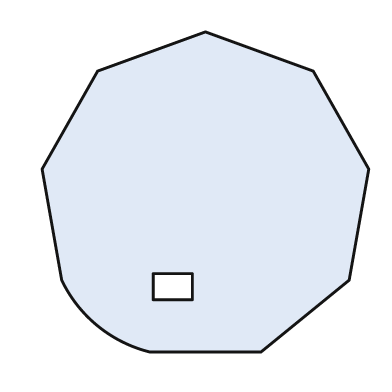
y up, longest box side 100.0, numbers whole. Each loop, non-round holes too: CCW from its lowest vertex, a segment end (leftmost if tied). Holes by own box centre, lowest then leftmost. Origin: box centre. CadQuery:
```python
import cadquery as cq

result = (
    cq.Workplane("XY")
    .moveTo(-17.0, -49.0)
    .lineTo(17.0, -49.0)
    .lineTo(44.0, -27.0)
    .lineTo(50.0, 7.0)
    .lineTo(33.0, 37.0)
    .lineTo(0.0, 49.0)
    .lineTo(-33.0, 37.0)
    .lineTo(-50.0, 7.0)
    .lineTo(-44.0, -27.0)
    .threePointArc((-33.0, -41.0), (-17.0, -49.0))
    .close()
    .moveTo(-16.0, -33.0)
    .lineTo(-4.0, -33.0)
    .lineTo(-4.0, -25.0)
    .lineTo(-16.0, -25.0)
    .close()
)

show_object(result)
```